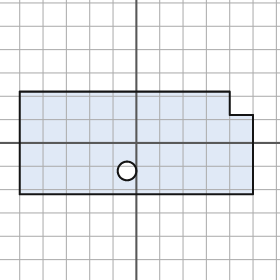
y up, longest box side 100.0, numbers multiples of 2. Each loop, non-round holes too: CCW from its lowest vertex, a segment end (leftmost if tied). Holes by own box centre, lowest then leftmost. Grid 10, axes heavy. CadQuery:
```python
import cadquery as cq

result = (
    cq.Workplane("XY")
    .moveTo(-50.0, -22.0)
    .lineTo(50.0, -22.0)
    .lineTo(50.0, 12.0)
    .lineTo(40.0, 12.0)
    .lineTo(40.0, 22.0)
    .lineTo(-50.0, 22.0)
    .close()
    .moveTo(-4.0, -12.0)
    .circle(4.0)
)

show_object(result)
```